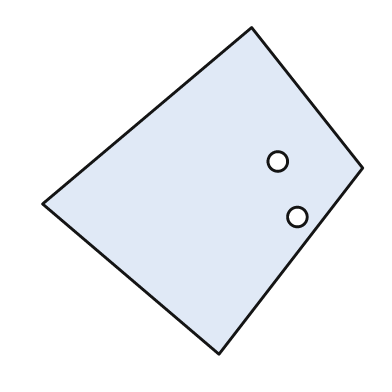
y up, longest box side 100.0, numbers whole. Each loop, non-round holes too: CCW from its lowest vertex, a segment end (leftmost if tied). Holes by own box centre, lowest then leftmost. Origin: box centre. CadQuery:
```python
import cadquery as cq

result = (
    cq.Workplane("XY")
    .moveTo(5.0, -50.0)
    .lineTo(49.0, 7.0)
    .lineTo(15.0, 50.0)
    .lineTo(-49.0, -4.0)
    .close()
    .moveTo(29.0, -8.0)
    .circle(3.0)
    .moveTo(23.0, 9.0)
    .circle(3.0)
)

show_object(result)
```